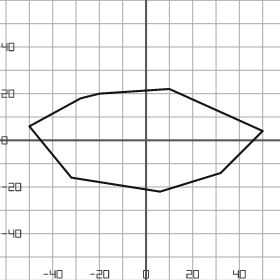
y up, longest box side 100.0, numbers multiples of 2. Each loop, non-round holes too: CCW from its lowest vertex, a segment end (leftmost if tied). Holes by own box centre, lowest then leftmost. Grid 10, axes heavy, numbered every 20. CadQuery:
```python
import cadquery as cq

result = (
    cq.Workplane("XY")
    .moveTo(6.0, -22.0)
    .lineTo(32.0, -14.0)
    .lineTo(50.0, 4.0)
    .lineTo(10.0, 22.0)
    .lineTo(-20.0, 20.0)
    .lineTo(-28.0, 18.0)
    .lineTo(-50.0, 6.0)
    .lineTo(-32.0, -16.0)
    .close()
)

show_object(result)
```